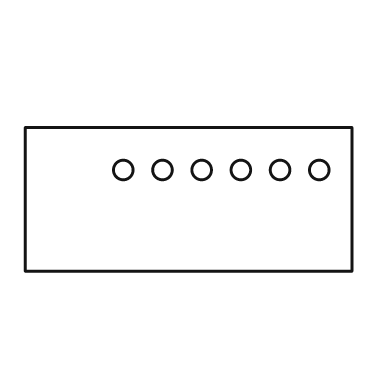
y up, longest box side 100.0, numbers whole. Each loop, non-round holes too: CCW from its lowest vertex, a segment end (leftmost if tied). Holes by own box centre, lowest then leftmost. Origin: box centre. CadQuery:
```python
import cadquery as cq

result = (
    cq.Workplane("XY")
    .moveTo(-50.0, -22.0)
    .lineTo(50.0, -22.0)
    .lineTo(50.0, 22.0)
    .lineTo(-50.0, 22.0)
    .close()
    .moveTo(-20.0, 9.0)
    .circle(3.0)
    .moveTo(-8.0, 9.0)
    .circle(3.0)
    .moveTo(4.0, 9.0)
    .circle(3.0)
    .moveTo(16.0, 9.0)
    .circle(3.0)
    .moveTo(28.0, 9.0)
    .circle(3.0)
    .moveTo(40.0, 9.0)
    .circle(3.0)
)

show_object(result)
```